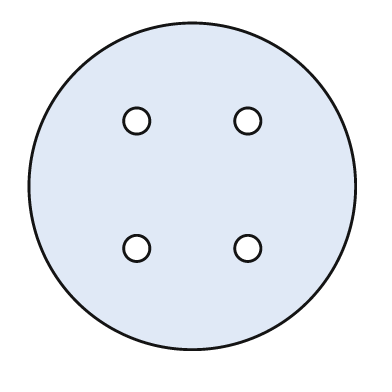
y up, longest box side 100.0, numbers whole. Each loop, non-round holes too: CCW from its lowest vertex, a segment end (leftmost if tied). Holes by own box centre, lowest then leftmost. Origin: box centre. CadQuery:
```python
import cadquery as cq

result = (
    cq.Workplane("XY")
    .moveTo(0.0, 0.0)
    .circle(50.0)
    .moveTo(-17.0, -19.0)
    .circle(4.0)
    .moveTo(17.0, -19.0)
    .circle(4.0)
    .moveTo(-17.0, 20.0)
    .circle(4.0)
    .moveTo(17.0, 20.0)
    .circle(4.0)
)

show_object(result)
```